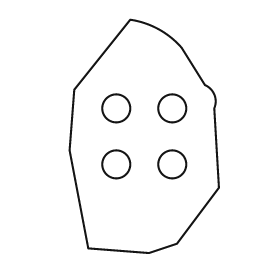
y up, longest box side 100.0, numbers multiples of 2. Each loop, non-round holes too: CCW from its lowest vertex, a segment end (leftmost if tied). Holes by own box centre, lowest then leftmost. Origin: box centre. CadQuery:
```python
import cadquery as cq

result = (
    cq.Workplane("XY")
    .moveTo(2.0, -50.0)
    .lineTo(14.0, -46.0)
    .lineTo(32.0, -22.0)
    .lineTo(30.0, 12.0)
    .threePointArc((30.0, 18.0), (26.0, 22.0))
    .lineTo(16.0, 38.0)
    .threePointArc((6.0, 46.0), (-6.0, 50.0))
    .lineTo(-30.0, 20.0)
    .lineTo(-32.0, -6.0)
    .lineTo(-24.0, -48.0)
    .close()
    .moveTo(-12.0, -12.0)
    .circle(6.0)
    .moveTo(12.0, -12.0)
    .circle(6.0)
    .moveTo(-12.0, 12.0)
    .circle(6.0)
    .moveTo(12.0, 12.0)
    .circle(6.0)
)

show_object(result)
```